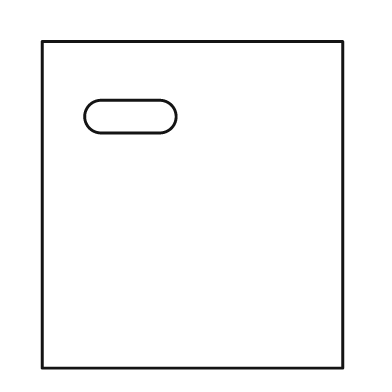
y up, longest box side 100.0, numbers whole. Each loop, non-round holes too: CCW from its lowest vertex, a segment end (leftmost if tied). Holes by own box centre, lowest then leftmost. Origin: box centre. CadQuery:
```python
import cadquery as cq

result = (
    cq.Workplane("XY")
    .moveTo(-46.0, -50.0)
    .lineTo(46.0, -50.0)
    .lineTo(46.0, 50.0)
    .lineTo(-46.0, 50.0)
    .close()
    .moveTo(-28.0, 22.0)
    .lineTo(-10.0, 22.0)
    .threePointArc((-5.0, 27.0), (-10.0, 32.0))
    .lineTo(-28.0, 32.0)
    .threePointArc((-33.0, 27.0), (-28.0, 22.0))
    .close()
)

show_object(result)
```